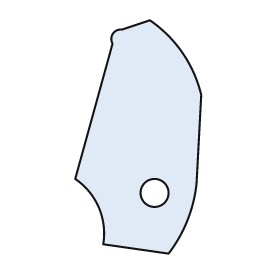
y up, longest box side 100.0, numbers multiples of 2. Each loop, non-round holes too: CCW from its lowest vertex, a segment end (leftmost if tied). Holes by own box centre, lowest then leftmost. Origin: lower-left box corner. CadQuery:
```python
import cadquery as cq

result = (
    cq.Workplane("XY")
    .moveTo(40.0, 0.0)
    .threePointArc((48.0, 14.0), (52.0, 30.0))
    .lineTo(54.0, 68.0)
    .threePointArc((46.0, 86.0), (32.0, 100.0))
    .lineTo(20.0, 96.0)
    .threePointArc((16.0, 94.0), (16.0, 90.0))
    .lineTo(0.0, 32.0)
    .threePointArc((10.0, 20.0), (12.0, 4.0))
    .close()
    .moveTo(34.0, 26.0)
    .circle(6.0)
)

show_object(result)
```